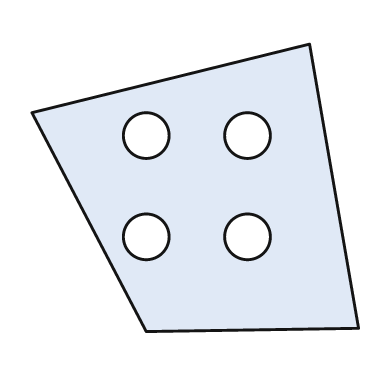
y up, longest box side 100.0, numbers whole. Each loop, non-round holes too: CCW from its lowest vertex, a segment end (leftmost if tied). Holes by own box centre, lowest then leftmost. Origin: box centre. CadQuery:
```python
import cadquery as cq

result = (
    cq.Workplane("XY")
    .moveTo(-15.0, -44.0)
    .lineTo(50.0, -43.0)
    .lineTo(35.0, 44.0)
    .lineTo(-50.0, 23.0)
    .close()
    .moveTo(-15.0, -15.0)
    .circle(7.0)
    .moveTo(16.0, -15.0)
    .circle(7.0)
    .moveTo(-15.0, 16.0)
    .circle(7.0)
    .moveTo(16.0, 16.0)
    .circle(7.0)
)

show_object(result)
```